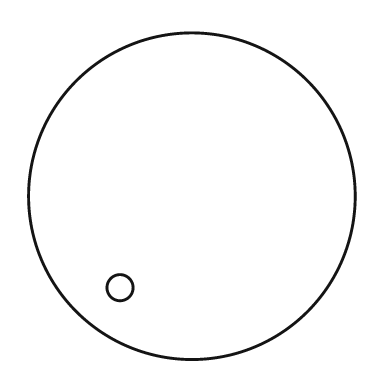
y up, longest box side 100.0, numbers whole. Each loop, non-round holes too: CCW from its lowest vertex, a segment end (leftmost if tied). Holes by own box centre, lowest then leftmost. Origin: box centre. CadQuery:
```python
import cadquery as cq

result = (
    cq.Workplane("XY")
    .moveTo(0.0, 0.0)
    .circle(50.0)
    .moveTo(-22.0, -28.0)
    .circle(4.0)
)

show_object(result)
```